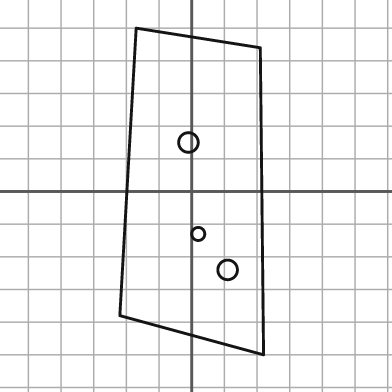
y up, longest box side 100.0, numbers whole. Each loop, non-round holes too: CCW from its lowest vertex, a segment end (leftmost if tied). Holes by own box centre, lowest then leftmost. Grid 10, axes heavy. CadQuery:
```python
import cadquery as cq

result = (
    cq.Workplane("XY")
    .moveTo(22.0, -50.0)
    .lineTo(21.0, 44.0)
    .lineTo(-17.0, 50.0)
    .lineTo(-22.0, -38.0)
    .close()
    .moveTo(11.0, -24.0)
    .circle(3.0)
    .moveTo(2.0, -13.0)
    .circle(2.0)
    .moveTo(-1.0, 15.0)
    .circle(3.0)
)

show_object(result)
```